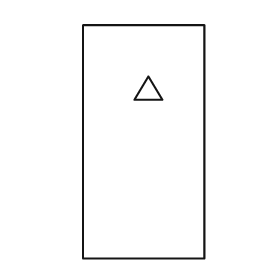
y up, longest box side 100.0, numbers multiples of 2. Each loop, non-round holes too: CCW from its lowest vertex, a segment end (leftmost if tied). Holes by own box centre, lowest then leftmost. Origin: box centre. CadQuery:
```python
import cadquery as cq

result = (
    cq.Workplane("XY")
    .moveTo(-26.0, -50.0)
    .lineTo(26.0, -50.0)
    .lineTo(26.0, 50.0)
    .lineTo(-26.0, 50.0)
    .close()
    .moveTo(-4.0, 18.0)
    .lineTo(8.0, 18.0)
    .lineTo(2.0, 28.0)
    .close()
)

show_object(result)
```